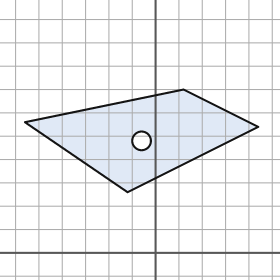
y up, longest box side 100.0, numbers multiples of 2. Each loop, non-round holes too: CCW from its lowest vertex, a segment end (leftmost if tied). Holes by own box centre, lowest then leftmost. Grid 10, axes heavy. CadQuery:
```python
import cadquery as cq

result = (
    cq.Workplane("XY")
    .moveTo(-12.0, 26.0)
    .lineTo(44.0, 54.0)
    .lineTo(12.0, 70.0)
    .lineTo(-56.0, 56.0)
    .close()
    .moveTo(-6.0, 48.0)
    .circle(4.0)
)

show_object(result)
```